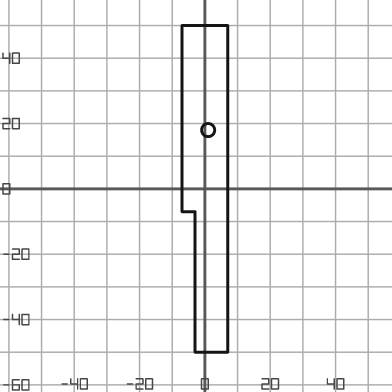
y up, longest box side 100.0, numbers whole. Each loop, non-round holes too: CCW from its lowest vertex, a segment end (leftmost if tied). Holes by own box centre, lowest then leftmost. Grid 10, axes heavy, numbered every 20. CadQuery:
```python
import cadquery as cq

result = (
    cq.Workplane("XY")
    .moveTo(-3.0, -50.0)
    .lineTo(7.0, -50.0)
    .lineTo(7.0, 50.0)
    .lineTo(-7.0, 50.0)
    .lineTo(-7.0, -7.0)
    .lineTo(-3.0, -7.0)
    .close()
    .moveTo(1.0, 18.0)
    .circle(2.0)
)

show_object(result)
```